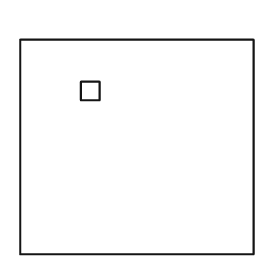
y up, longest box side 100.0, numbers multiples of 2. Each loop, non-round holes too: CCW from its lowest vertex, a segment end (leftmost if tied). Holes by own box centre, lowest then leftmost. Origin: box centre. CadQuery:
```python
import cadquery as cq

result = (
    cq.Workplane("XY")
    .moveTo(-50.0, -46.0)
    .lineTo(50.0, -46.0)
    .lineTo(50.0, 46.0)
    .lineTo(-50.0, 46.0)
    .close()
    .moveTo(-24.0, 20.0)
    .lineTo(-16.0, 20.0)
    .lineTo(-16.0, 28.0)
    .lineTo(-24.0, 28.0)
    .close()
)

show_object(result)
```